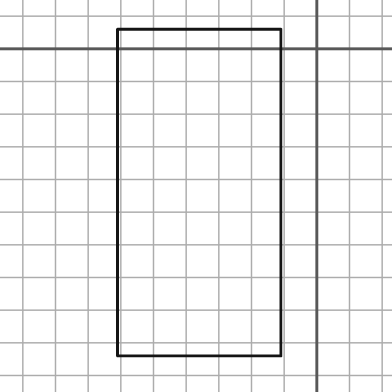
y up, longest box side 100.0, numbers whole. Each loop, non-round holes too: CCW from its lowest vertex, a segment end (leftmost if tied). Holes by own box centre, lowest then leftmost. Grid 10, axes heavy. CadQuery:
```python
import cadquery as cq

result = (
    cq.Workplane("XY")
    .moveTo(-61.0, -94.0)
    .lineTo(-11.0, -94.0)
    .lineTo(-11.0, 6.0)
    .lineTo(-61.0, 6.0)
    .close()
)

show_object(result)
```